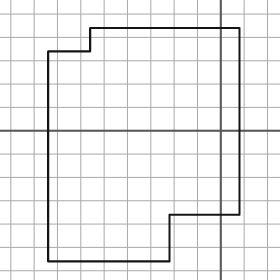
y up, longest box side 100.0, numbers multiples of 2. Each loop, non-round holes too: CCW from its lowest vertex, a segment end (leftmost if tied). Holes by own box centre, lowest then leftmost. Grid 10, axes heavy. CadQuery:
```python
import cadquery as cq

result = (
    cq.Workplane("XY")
    .moveTo(-74.0, -56.0)
    .lineTo(-22.0, -56.0)
    .lineTo(-22.0, -36.0)
    .lineTo(8.0, -36.0)
    .lineTo(8.0, 44.0)
    .lineTo(-56.0, 44.0)
    .lineTo(-56.0, 34.0)
    .lineTo(-74.0, 34.0)
    .close()
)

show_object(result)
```